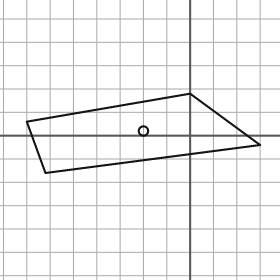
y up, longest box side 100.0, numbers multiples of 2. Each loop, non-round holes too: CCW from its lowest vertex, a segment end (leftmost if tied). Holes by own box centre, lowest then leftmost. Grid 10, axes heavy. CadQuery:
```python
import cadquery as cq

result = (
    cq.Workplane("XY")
    .moveTo(-62.0, -16.0)
    .lineTo(30.0, -4.0)
    .lineTo(0.0, 18.0)
    .lineTo(-70.0, 6.0)
    .close()
    .moveTo(-20.0, 2.0)
    .circle(2.0)
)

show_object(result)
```